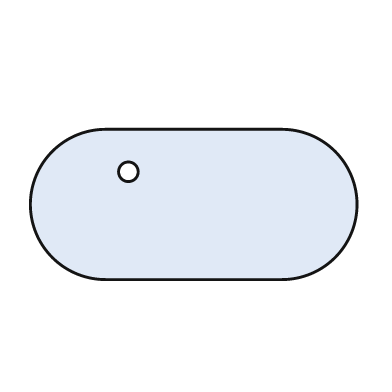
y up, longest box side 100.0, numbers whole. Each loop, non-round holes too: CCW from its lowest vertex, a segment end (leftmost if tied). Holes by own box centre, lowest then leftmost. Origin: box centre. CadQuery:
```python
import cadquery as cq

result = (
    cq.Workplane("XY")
    .moveTo(-27.0, -23.0)
    .lineTo(27.0, -23.0)
    .threePointArc((50.0, 0.0), (27.0, 23.0))
    .lineTo(-27.0, 23.0)
    .threePointArc((-50.0, 0.0), (-27.0, -23.0))
    .close()
    .moveTo(-20.0, 10.0)
    .circle(3.0)
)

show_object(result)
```